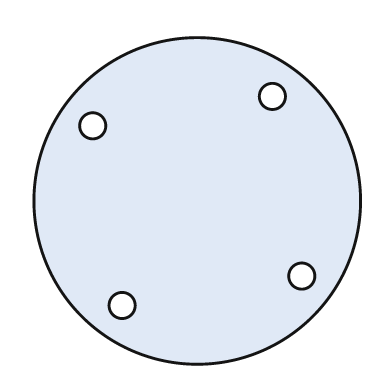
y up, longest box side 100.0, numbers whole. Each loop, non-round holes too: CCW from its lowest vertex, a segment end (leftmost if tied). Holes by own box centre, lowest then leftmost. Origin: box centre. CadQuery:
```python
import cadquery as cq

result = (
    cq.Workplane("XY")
    .moveTo(0.0, 0.0)
    .circle(50.0)
    .moveTo(-23.0, -32.0)
    .circle(4.0)
    .moveTo(32.0, -23.0)
    .circle(4.0)
    .moveTo(-32.0, 23.0)
    .circle(4.0)
    .moveTo(23.0, 32.0)
    .circle(4.0)
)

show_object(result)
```